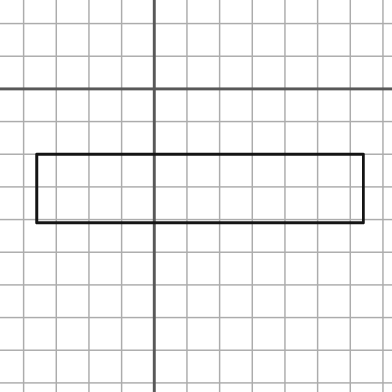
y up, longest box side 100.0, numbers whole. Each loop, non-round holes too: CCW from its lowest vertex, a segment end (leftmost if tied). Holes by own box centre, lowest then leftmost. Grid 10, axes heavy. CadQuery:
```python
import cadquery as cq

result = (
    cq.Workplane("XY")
    .moveTo(-36.0, -41.0)
    .lineTo(64.0, -41.0)
    .lineTo(64.0, -20.0)
    .lineTo(-36.0, -20.0)
    .close()
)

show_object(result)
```